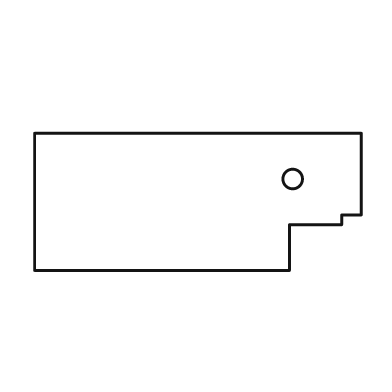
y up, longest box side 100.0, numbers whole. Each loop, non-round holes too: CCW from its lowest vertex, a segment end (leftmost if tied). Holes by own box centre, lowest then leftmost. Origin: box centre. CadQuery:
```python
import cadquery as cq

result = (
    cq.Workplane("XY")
    .moveTo(-50.0, -21.0)
    .lineTo(28.0, -21.0)
    .lineTo(28.0, -7.0)
    .lineTo(44.0, -7.0)
    .lineTo(44.0, -4.0)
    .lineTo(50.0, -4.0)
    .lineTo(50.0, 21.0)
    .lineTo(-50.0, 21.0)
    .close()
    .moveTo(29.0, 7.0)
    .circle(3.0)
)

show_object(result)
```